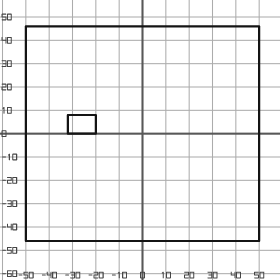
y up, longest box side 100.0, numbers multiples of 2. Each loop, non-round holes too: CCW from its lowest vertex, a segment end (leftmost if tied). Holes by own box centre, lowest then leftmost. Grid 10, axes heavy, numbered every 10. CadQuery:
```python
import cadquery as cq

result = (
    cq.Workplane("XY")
    .moveTo(-50.0, -46.0)
    .lineTo(50.0, -46.0)
    .lineTo(50.0, 46.0)
    .lineTo(-50.0, 46.0)
    .close()
    .moveTo(-32.0, 0.0)
    .lineTo(-20.0, 0.0)
    .lineTo(-20.0, 8.0)
    .lineTo(-32.0, 8.0)
    .close()
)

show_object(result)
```